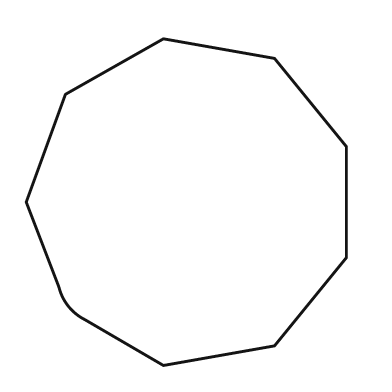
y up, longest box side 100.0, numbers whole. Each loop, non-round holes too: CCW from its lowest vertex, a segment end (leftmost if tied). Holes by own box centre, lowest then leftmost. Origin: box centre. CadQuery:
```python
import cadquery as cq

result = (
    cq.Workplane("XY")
    .moveTo(-7.0, -50.0)
    .lineTo(27.0, -44.0)
    .lineTo(49.0, -17.0)
    .lineTo(49.0, 17.0)
    .lineTo(27.0, 44.0)
    .lineTo(-7.0, 50.0)
    .lineTo(-37.0, 33.0)
    .lineTo(-49.0, 0.0)
    .lineTo(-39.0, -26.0)
    .threePointArc((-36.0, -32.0), (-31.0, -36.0))
    .close()
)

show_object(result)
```